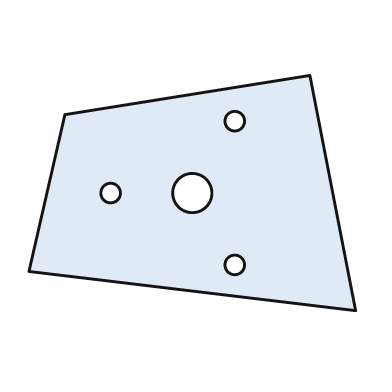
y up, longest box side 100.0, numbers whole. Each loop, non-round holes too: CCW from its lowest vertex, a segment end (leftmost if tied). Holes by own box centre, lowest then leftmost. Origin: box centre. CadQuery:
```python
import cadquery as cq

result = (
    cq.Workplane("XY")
    .moveTo(50.0, -36.0)
    .lineTo(36.0, 36.0)
    .lineTo(-39.0, 24.0)
    .lineTo(-50.0, -24.0)
    .close()
    .moveTo(13.0, -22.0)
    .circle(3.0)
    .moveTo(-25.0, 0.0)
    .circle(3.0)
    .moveTo(0.0, 0.0)
    .circle(6.0)
    .moveTo(13.0, 22.0)
    .circle(3.0)
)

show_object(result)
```